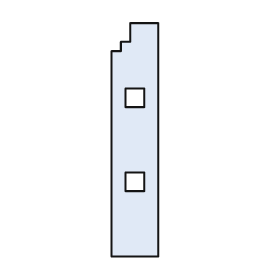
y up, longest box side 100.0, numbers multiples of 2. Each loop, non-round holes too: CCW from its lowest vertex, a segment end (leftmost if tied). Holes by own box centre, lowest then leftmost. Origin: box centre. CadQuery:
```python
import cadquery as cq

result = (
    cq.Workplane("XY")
    .moveTo(-10.0, -50.0)
    .lineTo(10.0, -50.0)
    .lineTo(10.0, 50.0)
    .lineTo(-2.0, 50.0)
    .lineTo(-2.0, 42.0)
    .lineTo(-6.0, 42.0)
    .lineTo(-6.0, 38.0)
    .lineTo(-10.0, 38.0)
    .close()
    .moveTo(-4.0, -22.0)
    .lineTo(4.0, -22.0)
    .lineTo(4.0, -14.0)
    .lineTo(-4.0, -14.0)
    .close()
    .moveTo(-4.0, 14.0)
    .lineTo(4.0, 14.0)
    .lineTo(4.0, 22.0)
    .lineTo(-4.0, 22.0)
    .close()
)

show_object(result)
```